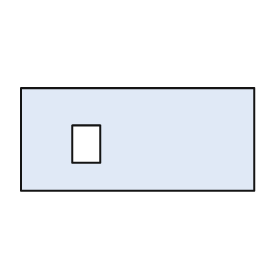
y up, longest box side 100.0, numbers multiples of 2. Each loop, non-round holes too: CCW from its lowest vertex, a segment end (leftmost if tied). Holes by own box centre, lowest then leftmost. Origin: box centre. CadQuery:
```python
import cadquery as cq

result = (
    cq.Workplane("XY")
    .moveTo(-50.0, -22.0)
    .lineTo(50.0, -22.0)
    .lineTo(50.0, 22.0)
    .lineTo(-50.0, 22.0)
    .close()
    .moveTo(-28.0, -10.0)
    .lineTo(-16.0, -10.0)
    .lineTo(-16.0, 6.0)
    .lineTo(-28.0, 6.0)
    .close()
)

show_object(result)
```